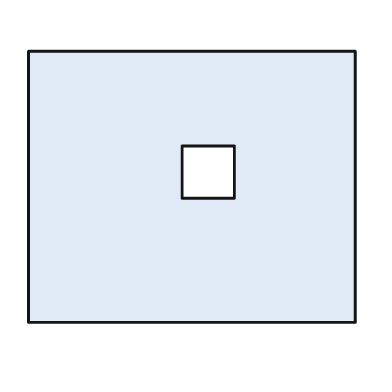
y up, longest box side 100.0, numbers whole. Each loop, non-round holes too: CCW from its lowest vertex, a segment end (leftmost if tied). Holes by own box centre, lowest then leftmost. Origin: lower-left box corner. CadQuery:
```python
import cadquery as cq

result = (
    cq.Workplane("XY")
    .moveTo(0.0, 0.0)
    .lineTo(100.0, 0.0)
    .lineTo(100.0, 83.0)
    .lineTo(0.0, 83.0)
    .close()
    .moveTo(47.0, 38.0)
    .lineTo(63.0, 38.0)
    .lineTo(63.0, 54.0)
    .lineTo(47.0, 54.0)
    .close()
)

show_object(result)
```